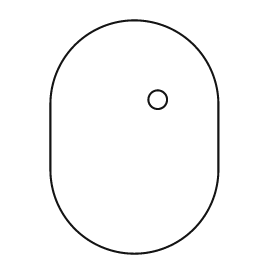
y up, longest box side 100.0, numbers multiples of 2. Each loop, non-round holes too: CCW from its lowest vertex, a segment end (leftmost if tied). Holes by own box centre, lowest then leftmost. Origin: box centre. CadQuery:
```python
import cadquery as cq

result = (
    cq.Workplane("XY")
    .moveTo(-36.0, -14.0)
    .threePointArc((0.0, -50.0), (36.0, -14.0))
    .lineTo(36.0, 14.0)
    .threePointArc((0.0, 50.0), (-36.0, 14.0))
    .close()
    .moveTo(10.0, 16.0)
    .circle(4.0)
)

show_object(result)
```